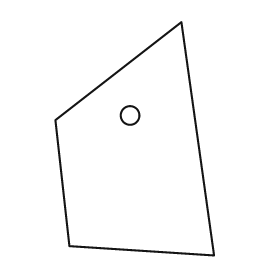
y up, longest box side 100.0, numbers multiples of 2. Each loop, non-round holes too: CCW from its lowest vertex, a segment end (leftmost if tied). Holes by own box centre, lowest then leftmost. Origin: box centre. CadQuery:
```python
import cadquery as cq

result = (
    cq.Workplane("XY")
    .moveTo(34.0, -50.0)
    .lineTo(20.0, 50.0)
    .lineTo(-34.0, 8.0)
    .lineTo(-28.0, -46.0)
    .close()
    .moveTo(-2.0, 10.0)
    .circle(4.0)
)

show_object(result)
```